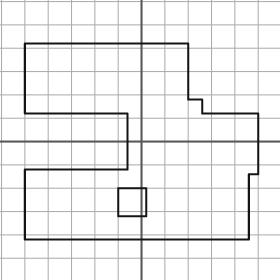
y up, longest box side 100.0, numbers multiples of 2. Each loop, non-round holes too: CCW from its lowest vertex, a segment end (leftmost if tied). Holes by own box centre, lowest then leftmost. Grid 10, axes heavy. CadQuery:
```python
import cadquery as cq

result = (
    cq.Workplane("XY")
    .moveTo(-50.0, -42.0)
    .lineTo(46.0, -42.0)
    .lineTo(46.0, -14.0)
    .lineTo(50.0, -14.0)
    .lineTo(50.0, 12.0)
    .lineTo(26.0, 12.0)
    .lineTo(26.0, 18.0)
    .lineTo(20.0, 18.0)
    .lineTo(20.0, 42.0)
    .lineTo(-50.0, 42.0)
    .lineTo(-50.0, 12.0)
    .lineTo(-6.0, 12.0)
    .lineTo(-6.0, -12.0)
    .lineTo(-50.0, -12.0)
    .close()
    .moveTo(-10.0, -32.0)
    .lineTo(2.0, -32.0)
    .lineTo(2.0, -20.0)
    .lineTo(-10.0, -20.0)
    .close()
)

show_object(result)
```